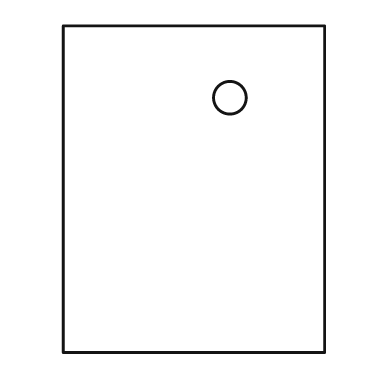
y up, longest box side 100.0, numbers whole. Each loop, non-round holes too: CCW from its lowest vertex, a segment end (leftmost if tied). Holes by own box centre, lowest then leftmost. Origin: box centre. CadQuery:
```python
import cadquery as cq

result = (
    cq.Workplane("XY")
    .moveTo(-40.0, -50.0)
    .lineTo(40.0, -50.0)
    .lineTo(40.0, 50.0)
    .lineTo(-40.0, 50.0)
    .close()
    .moveTo(11.0, 28.0)
    .circle(5.0)
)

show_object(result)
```